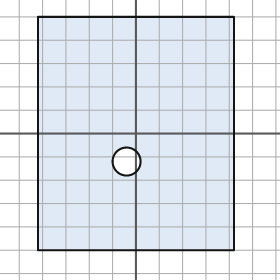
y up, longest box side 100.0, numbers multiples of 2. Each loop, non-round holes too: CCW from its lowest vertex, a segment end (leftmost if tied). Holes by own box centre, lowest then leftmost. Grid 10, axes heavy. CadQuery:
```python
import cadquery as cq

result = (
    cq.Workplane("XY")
    .moveTo(-42.0, -50.0)
    .lineTo(42.0, -50.0)
    .lineTo(42.0, 50.0)
    .lineTo(-42.0, 50.0)
    .close()
    .moveTo(-4.0, -12.0)
    .circle(6.0)
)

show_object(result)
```